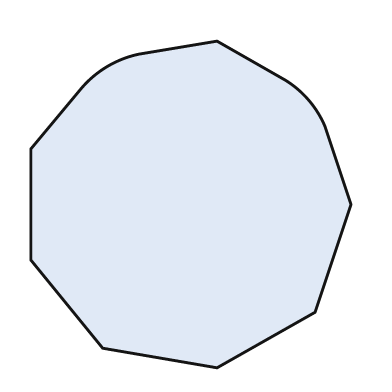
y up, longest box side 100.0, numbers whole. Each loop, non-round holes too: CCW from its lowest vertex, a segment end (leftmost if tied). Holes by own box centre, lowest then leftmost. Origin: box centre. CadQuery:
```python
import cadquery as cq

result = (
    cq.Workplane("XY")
    .moveTo(8.0, -50.0)
    .lineTo(38.0, -33.0)
    .lineTo(49.0, 0.0)
    .lineTo(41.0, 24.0)
    .threePointArc((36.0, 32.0), (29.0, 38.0))
    .lineTo(8.0, 50.0)
    .lineTo(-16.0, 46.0)
    .threePointArc((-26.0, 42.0), (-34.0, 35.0))
    .lineTo(-49.0, 17.0)
    .lineTo(-49.0, -17.0)
    .lineTo(-27.0, -44.0)
    .close()
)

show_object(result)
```